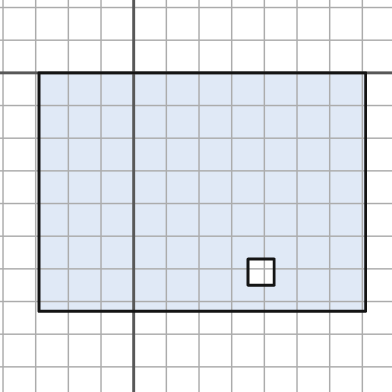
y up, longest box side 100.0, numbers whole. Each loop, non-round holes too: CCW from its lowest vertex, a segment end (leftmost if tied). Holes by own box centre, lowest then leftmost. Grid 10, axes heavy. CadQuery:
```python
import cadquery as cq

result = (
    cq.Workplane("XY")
    .moveTo(-29.0, -73.0)
    .lineTo(71.0, -73.0)
    .lineTo(71.0, 0.0)
    .lineTo(-29.0, 0.0)
    .close()
    .moveTo(35.0, -65.0)
    .lineTo(43.0, -65.0)
    .lineTo(43.0, -57.0)
    .lineTo(35.0, -57.0)
    .close()
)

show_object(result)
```